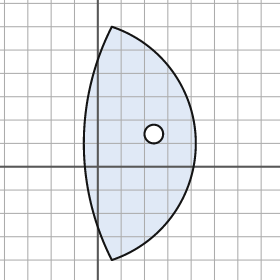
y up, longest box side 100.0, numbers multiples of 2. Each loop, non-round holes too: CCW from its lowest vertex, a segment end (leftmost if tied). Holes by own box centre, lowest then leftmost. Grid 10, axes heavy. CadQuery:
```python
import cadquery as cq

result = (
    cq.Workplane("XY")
    .moveTo(6.0, -40.0)
    .threePointArc((42.0, 10.0), (6.0, 60.0))
    .threePointArc((-6.0, 10.0), (6.0, -40.0))
    .close()
    .moveTo(24.0, 14.0)
    .circle(4.0)
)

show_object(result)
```